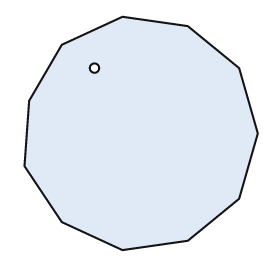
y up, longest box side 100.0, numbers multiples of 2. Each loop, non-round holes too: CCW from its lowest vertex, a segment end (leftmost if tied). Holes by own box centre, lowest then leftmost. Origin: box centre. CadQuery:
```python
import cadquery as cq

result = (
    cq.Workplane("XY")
    .moveTo(-8.0, -50.0)
    .lineTo(20.0, -46.0)
    .lineTo(42.0, -28.0)
    .lineTo(50.0, 0.0)
    .lineTo(42.0, 28.0)
    .lineTo(20.0, 46.0)
    .lineTo(-8.0, 50.0)
    .lineTo(-34.0, 38.0)
    .lineTo(-48.0, 14.0)
    .lineTo(-50.0, -14.0)
    .lineTo(-34.0, -38.0)
    .close()
    .moveTo(-20.0, 28.0)
    .circle(2.0)
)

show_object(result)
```